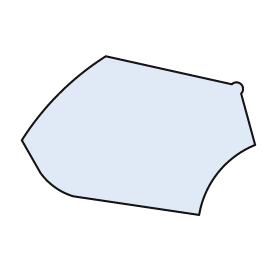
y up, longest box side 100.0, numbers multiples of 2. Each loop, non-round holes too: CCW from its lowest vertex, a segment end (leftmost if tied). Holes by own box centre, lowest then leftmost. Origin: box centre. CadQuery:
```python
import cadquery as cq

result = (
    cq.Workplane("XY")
    .moveTo(26.0, -34.0)
    .threePointArc((34.0, -16.0), (50.0, -4.0))
    .lineTo(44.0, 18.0)
    .threePointArc((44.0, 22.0), (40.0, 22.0))
    .lineTo(-14.0, 34.0)
    .threePointArc((-34.0, 18.0), (-50.0, -2.0))
    .lineTo(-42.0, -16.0)
    .threePointArc((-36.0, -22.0), (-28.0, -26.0))
    .close()
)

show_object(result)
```